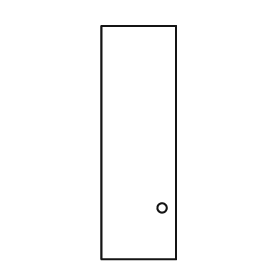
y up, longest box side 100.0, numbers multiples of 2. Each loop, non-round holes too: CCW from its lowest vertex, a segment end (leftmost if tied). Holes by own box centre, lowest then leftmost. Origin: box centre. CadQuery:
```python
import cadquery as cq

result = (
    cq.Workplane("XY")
    .moveTo(-16.0, -50.0)
    .lineTo(16.0, -50.0)
    .lineTo(16.0, 50.0)
    .lineTo(-16.0, 50.0)
    .close()
    .moveTo(10.0, -28.0)
    .circle(2.0)
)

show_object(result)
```